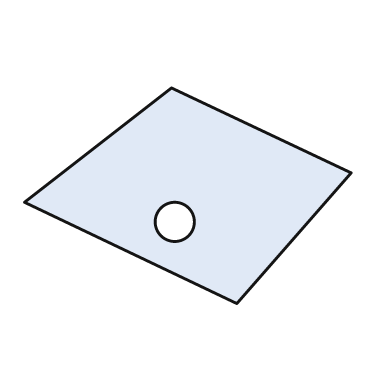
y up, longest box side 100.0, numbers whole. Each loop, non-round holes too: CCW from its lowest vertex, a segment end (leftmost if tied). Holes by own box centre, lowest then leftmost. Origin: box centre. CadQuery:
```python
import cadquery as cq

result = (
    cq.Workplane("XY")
    .moveTo(15.0, -33.0)
    .lineTo(50.0, 7.0)
    .lineTo(-5.0, 33.0)
    .lineTo(-50.0, -2.0)
    .close()
    .moveTo(-4.0, -8.0)
    .circle(6.0)
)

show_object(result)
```